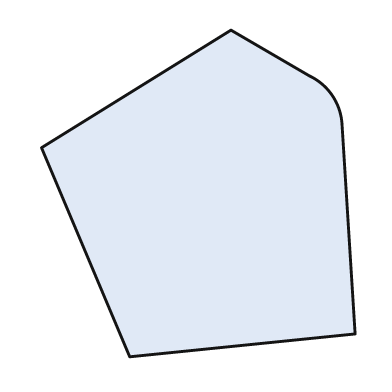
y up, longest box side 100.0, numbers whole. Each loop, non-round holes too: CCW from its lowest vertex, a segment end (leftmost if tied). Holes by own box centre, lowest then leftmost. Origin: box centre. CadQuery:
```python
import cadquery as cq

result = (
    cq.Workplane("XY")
    .moveTo(-21.0, -50.0)
    .lineTo(48.0, -43.0)
    .lineTo(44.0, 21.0)
    .threePointArc((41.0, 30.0), (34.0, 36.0))
    .lineTo(10.0, 50.0)
    .lineTo(-48.0, 14.0)
    .close()
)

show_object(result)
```